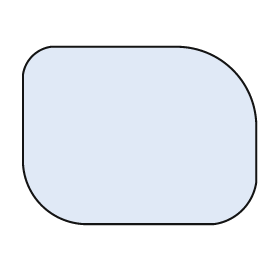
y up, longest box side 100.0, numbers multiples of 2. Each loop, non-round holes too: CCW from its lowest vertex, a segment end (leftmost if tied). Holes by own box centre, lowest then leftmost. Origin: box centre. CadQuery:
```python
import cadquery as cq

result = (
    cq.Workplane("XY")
    .moveTo(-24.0, -38.0)
    .lineTo(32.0, -38.0)
    .threePointArc((44.0, -32.0), (50.0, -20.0))
    .lineTo(50.0, 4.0)
    .threePointArc((40.0, 28.0), (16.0, 38.0))
    .lineTo(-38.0, 38.0)
    .threePointArc((-46.0, 34.0), (-50.0, 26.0))
    .lineTo(-50.0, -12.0)
    .threePointArc((-42.0, -30.0), (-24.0, -38.0))
    .close()
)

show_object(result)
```